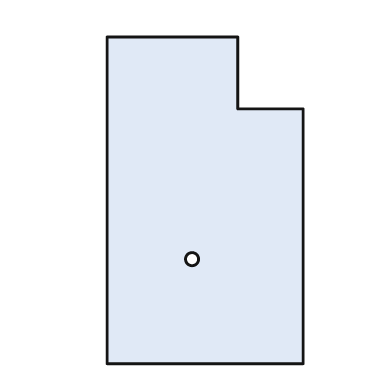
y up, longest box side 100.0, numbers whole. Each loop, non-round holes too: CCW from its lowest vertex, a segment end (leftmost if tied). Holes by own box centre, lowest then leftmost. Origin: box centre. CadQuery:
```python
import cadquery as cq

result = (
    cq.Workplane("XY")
    .moveTo(-30.0, -50.0)
    .lineTo(30.0, -50.0)
    .lineTo(30.0, 28.0)
    .lineTo(10.0, 28.0)
    .lineTo(10.0, 50.0)
    .lineTo(-30.0, 50.0)
    .close()
    .moveTo(-4.0, -18.0)
    .circle(2.0)
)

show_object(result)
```